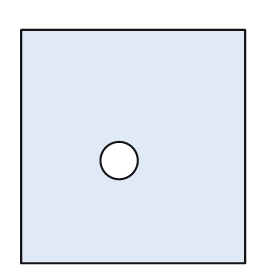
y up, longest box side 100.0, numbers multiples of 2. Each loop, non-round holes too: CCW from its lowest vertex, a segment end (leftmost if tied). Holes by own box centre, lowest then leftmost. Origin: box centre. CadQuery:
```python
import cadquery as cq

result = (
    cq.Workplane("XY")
    .moveTo(-48.0, -50.0)
    .lineTo(48.0, -50.0)
    .lineTo(48.0, 50.0)
    .lineTo(-48.0, 50.0)
    .close()
    .moveTo(-6.0, -6.0)
    .circle(8.0)
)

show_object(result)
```